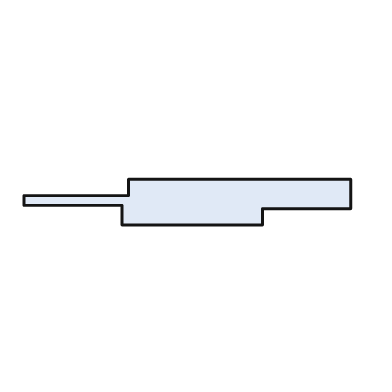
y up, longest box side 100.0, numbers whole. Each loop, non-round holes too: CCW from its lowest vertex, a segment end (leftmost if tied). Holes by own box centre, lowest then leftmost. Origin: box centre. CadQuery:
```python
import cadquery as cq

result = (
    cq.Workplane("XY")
    .moveTo(-20.0, -7.0)
    .lineTo(23.0, -7.0)
    .lineTo(23.0, -2.0)
    .lineTo(50.0, -2.0)
    .lineTo(50.0, 7.0)
    .lineTo(-18.0, 7.0)
    .lineTo(-18.0, 2.0)
    .lineTo(-50.0, 2.0)
    .lineTo(-50.0, -1.0)
    .lineTo(-20.0, -1.0)
    .close()
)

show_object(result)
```